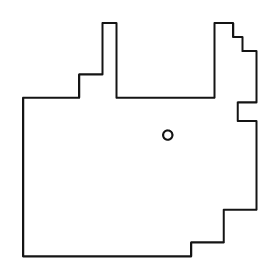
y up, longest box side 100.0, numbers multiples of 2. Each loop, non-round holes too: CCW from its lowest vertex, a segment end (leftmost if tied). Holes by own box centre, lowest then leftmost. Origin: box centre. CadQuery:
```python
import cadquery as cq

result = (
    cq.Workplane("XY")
    .moveTo(-50.0, -50.0)
    .lineTo(22.0, -50.0)
    .lineTo(22.0, -44.0)
    .lineTo(36.0, -44.0)
    .lineTo(36.0, -30.0)
    .lineTo(50.0, -30.0)
    .lineTo(50.0, 8.0)
    .lineTo(42.0, 8.0)
    .lineTo(42.0, 16.0)
    .lineTo(50.0, 16.0)
    .lineTo(50.0, 38.0)
    .lineTo(44.0, 38.0)
    .lineTo(44.0, 44.0)
    .lineTo(40.0, 44.0)
    .lineTo(40.0, 50.0)
    .lineTo(32.0, 50.0)
    .lineTo(32.0, 18.0)
    .lineTo(-10.0, 18.0)
    .lineTo(-10.0, 50.0)
    .lineTo(-16.0, 50.0)
    .lineTo(-16.0, 28.0)
    .lineTo(-26.0, 28.0)
    .lineTo(-26.0, 18.0)
    .lineTo(-50.0, 18.0)
    .close()
    .moveTo(12.0, 2.0)
    .circle(2.0)
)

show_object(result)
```